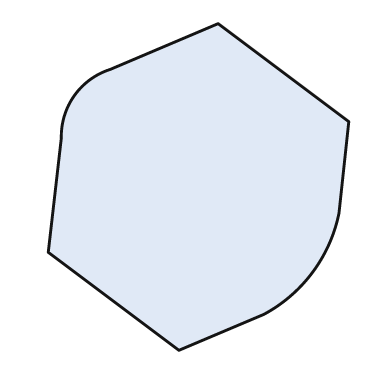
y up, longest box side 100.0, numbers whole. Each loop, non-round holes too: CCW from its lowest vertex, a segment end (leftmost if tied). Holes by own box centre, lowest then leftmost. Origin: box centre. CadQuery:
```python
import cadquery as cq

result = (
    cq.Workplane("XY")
    .moveTo(-6.0, -50.0)
    .lineTo(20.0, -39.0)
    .threePointArc((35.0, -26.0), (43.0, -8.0))
    .lineTo(46.0, 20.0)
    .lineTo(6.0, 50.0)
    .lineTo(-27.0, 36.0)
    .threePointArc((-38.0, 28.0), (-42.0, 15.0))
    .lineTo(-46.0, -20.0)
    .close()
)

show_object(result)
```